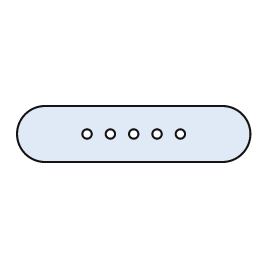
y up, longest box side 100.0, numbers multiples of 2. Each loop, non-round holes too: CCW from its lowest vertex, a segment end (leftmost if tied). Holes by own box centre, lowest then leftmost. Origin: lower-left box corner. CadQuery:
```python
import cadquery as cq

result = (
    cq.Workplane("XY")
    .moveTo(12.0, 0.0)
    .lineTo(88.0, 0.0)
    .threePointArc((100.0, 12.0), (88.0, 24.0))
    .lineTo(12.0, 24.0)
    .threePointArc((0.0, 12.0), (12.0, 0.0))
    .close()
    .moveTo(30.0, 12.0)
    .circle(2.0)
    .moveTo(40.0, 12.0)
    .circle(2.0)
    .moveTo(50.0, 12.0)
    .circle(2.0)
    .moveTo(60.0, 12.0)
    .circle(2.0)
    .moveTo(70.0, 12.0)
    .circle(2.0)
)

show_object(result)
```